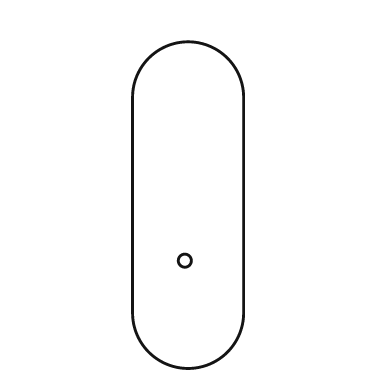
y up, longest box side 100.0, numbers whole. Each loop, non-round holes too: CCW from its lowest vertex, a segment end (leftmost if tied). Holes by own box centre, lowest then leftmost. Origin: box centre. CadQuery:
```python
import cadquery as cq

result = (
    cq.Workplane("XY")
    .moveTo(-17.0, -33.0)
    .threePointArc((0.0, -50.0), (17.0, -33.0))
    .lineTo(17.0, 33.0)
    .threePointArc((0.0, 50.0), (-17.0, 33.0))
    .close()
    .moveTo(-1.0, -17.0)
    .circle(2.0)
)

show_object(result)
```